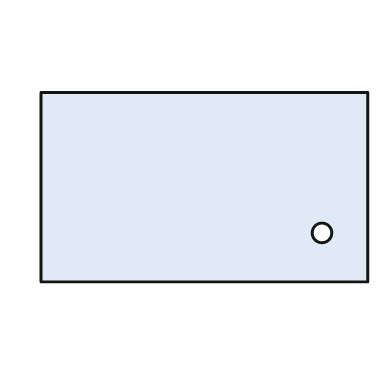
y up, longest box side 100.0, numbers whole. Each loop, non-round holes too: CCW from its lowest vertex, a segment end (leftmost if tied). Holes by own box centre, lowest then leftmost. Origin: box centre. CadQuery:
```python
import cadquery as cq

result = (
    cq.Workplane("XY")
    .moveTo(-50.0, -29.0)
    .lineTo(50.0, -29.0)
    .lineTo(50.0, 29.0)
    .lineTo(-50.0, 29.0)
    .close()
    .moveTo(36.0, -14.0)
    .circle(3.0)
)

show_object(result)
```